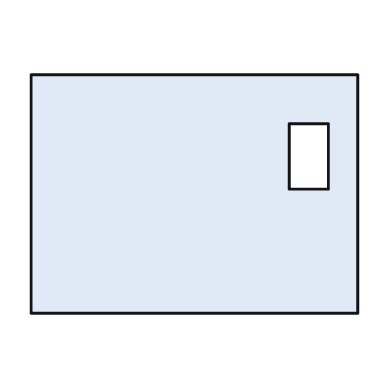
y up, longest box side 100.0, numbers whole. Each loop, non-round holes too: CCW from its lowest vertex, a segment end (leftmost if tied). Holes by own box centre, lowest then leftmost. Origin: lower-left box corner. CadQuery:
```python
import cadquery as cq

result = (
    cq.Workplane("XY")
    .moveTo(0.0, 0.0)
    .lineTo(100.0, 0.0)
    .lineTo(100.0, 73.0)
    .lineTo(0.0, 73.0)
    .close()
    .moveTo(79.0, 38.0)
    .lineTo(91.0, 38.0)
    .lineTo(91.0, 58.0)
    .lineTo(79.0, 58.0)
    .close()
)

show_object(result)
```